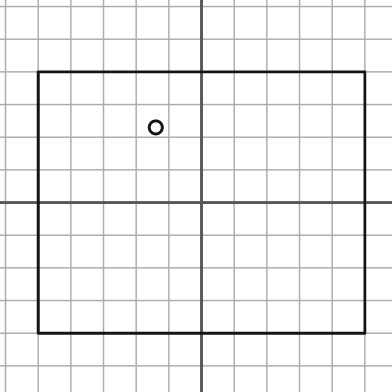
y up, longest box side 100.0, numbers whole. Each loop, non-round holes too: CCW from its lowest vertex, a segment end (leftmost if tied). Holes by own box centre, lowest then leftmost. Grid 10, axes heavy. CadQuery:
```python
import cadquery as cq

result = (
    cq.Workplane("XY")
    .moveTo(-50.0, -40.0)
    .lineTo(50.0, -40.0)
    .lineTo(50.0, 40.0)
    .lineTo(-50.0, 40.0)
    .close()
    .moveTo(-14.0, 23.0)
    .circle(2.0)
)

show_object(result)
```